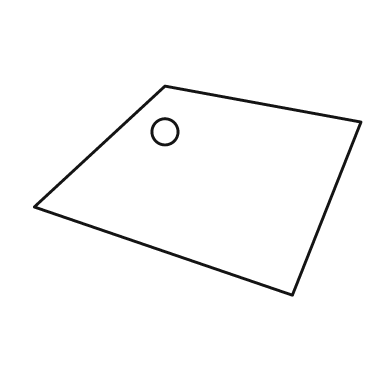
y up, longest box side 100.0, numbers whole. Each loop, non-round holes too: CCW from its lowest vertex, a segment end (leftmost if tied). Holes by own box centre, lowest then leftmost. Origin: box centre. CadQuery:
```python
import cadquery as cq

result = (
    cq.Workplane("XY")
    .moveTo(29.0, -32.0)
    .lineTo(50.0, 21.0)
    .lineTo(-10.0, 32.0)
    .lineTo(-50.0, -5.0)
    .close()
    .moveTo(-10.0, 18.0)
    .circle(4.0)
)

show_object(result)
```